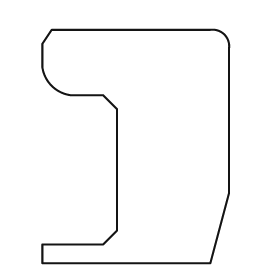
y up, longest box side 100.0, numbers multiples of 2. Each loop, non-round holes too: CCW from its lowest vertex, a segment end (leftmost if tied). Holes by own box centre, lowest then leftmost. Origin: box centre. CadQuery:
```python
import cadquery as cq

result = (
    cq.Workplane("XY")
    .moveTo(-40.0, -50.0)
    .lineTo(32.0, -50.0)
    .lineTo(40.0, -20.0)
    .lineTo(40.0, 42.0)
    .threePointArc((38.0, 48.0), (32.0, 50.0))
    .lineTo(-36.0, 50.0)
    .lineTo(-40.0, 44.0)
    .lineTo(-40.0, 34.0)
    .threePointArc((-36.0, 26.0), (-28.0, 22.0))
    .lineTo(-14.0, 22.0)
    .lineTo(-8.0, 16.0)
    .lineTo(-8.0, -36.0)
    .lineTo(-14.0, -42.0)
    .lineTo(-40.0, -42.0)
    .close()
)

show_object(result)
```